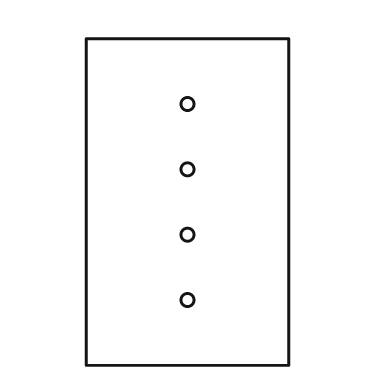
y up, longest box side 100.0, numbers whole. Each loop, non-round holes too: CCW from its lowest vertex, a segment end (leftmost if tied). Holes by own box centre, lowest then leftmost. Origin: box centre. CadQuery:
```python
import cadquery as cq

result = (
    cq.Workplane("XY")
    .moveTo(-31.0, -50.0)
    .lineTo(31.0, -50.0)
    .lineTo(31.0, 50.0)
    .lineTo(-31.0, 50.0)
    .close()
    .moveTo(0.0, -30.0)
    .circle(2.0)
    .moveTo(0.0, -10.0)
    .circle(2.0)
    .moveTo(0.0, 10.0)
    .circle(2.0)
    .moveTo(0.0, 30.0)
    .circle(2.0)
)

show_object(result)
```